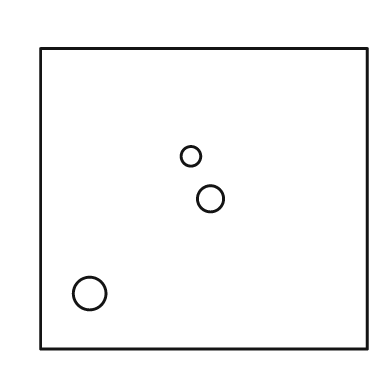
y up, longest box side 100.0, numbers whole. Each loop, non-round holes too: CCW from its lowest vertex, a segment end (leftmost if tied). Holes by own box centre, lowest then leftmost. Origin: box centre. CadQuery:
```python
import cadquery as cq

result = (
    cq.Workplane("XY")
    .moveTo(-50.0, -46.0)
    .lineTo(50.0, -46.0)
    .lineTo(50.0, 46.0)
    .lineTo(-50.0, 46.0)
    .close()
    .moveTo(-35.0, -29.0)
    .circle(5.0)
    .moveTo(2.0, 0.0)
    .circle(4.0)
    .moveTo(-4.0, 13.0)
    .circle(3.0)
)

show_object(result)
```